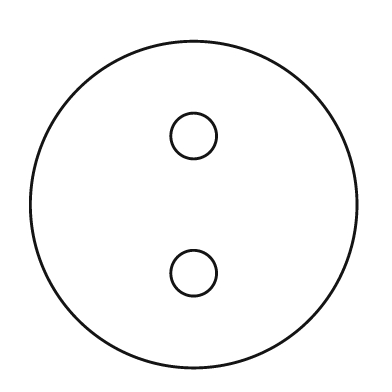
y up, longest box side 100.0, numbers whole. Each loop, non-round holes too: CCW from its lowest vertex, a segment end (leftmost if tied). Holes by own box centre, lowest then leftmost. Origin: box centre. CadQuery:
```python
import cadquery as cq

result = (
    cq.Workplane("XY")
    .moveTo(0.0, 0.0)
    .circle(50.0)
    .moveTo(0.0, -21.0)
    .circle(7.0)
    .moveTo(0.0, 21.0)
    .circle(7.0)
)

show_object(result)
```